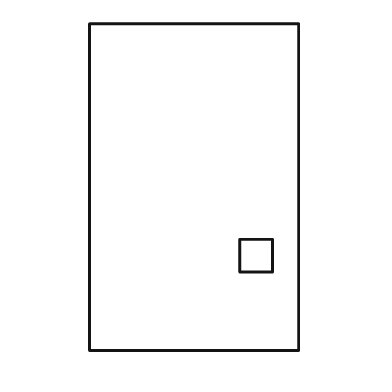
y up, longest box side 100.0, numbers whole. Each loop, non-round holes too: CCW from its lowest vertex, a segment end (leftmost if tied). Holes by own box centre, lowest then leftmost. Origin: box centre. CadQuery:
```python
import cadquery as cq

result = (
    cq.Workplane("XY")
    .moveTo(-32.0, -50.0)
    .lineTo(32.0, -50.0)
    .lineTo(32.0, 50.0)
    .lineTo(-32.0, 50.0)
    .close()
    .moveTo(14.0, -26.0)
    .lineTo(24.0, -26.0)
    .lineTo(24.0, -16.0)
    .lineTo(14.0, -16.0)
    .close()
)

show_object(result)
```